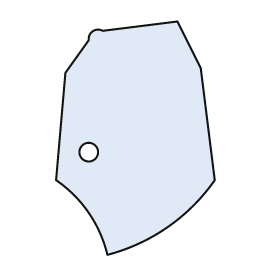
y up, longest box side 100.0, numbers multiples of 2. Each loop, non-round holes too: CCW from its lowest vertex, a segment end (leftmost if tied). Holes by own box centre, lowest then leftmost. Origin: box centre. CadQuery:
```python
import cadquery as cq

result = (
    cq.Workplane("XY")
    .moveTo(-12.0, -50.0)
    .threePointArc((14.0, -38.0), (34.0, -18.0))
    .lineTo(28.0, 30.0)
    .lineTo(18.0, 50.0)
    .lineTo(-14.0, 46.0)
    .threePointArc((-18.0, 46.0), (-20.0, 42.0))
    .lineTo(-30.0, 28.0)
    .lineTo(-34.0, -18.0)
    .threePointArc((-20.0, -32.0), (-12.0, -50.0))
    .close()
    .moveTo(-20.0, -6.0)
    .circle(4.0)
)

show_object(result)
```